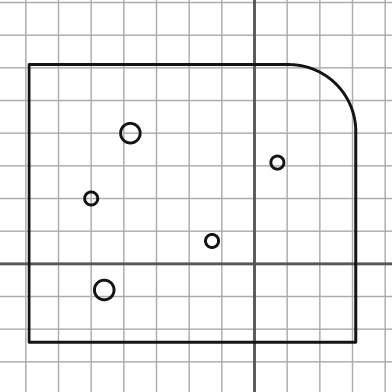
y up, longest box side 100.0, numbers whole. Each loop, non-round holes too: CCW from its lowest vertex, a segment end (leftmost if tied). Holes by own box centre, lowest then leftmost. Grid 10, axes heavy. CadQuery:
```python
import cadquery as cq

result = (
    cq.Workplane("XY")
    .moveTo(-69.0, -24.0)
    .lineTo(31.0, -24.0)
    .lineTo(31.0, 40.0)
    .threePointArc((25.0, 55.0), (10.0, 61.0))
    .lineTo(-69.0, 61.0)
    .close()
    .moveTo(-46.0, -8.0)
    .circle(3.0)
    .moveTo(-13.0, 7.0)
    .circle(2.0)
    .moveTo(-50.0, 20.0)
    .circle(2.0)
    .moveTo(7.0, 31.0)
    .circle(2.0)
    .moveTo(-38.0, 40.0)
    .circle(3.0)
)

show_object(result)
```